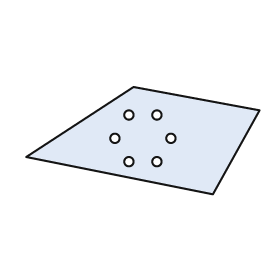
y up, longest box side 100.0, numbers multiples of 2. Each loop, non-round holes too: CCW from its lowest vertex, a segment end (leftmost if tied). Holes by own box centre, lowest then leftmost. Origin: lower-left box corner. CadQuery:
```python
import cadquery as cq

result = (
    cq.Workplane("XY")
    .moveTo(80.0, 0.0)
    .lineTo(100.0, 36.0)
    .lineTo(46.0, 46.0)
    .lineTo(0.0, 16.0)
    .close()
    .moveTo(44.0, 14.0)
    .circle(2.0)
    .moveTo(56.0, 14.0)
    .circle(2.0)
    .moveTo(38.0, 24.0)
    .circle(2.0)
    .moveTo(62.0, 24.0)
    .circle(2.0)
    .moveTo(44.0, 34.0)
    .circle(2.0)
    .moveTo(56.0, 34.0)
    .circle(2.0)
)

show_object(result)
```